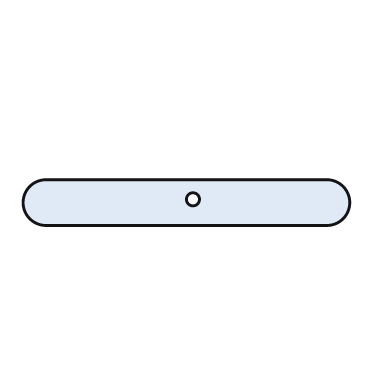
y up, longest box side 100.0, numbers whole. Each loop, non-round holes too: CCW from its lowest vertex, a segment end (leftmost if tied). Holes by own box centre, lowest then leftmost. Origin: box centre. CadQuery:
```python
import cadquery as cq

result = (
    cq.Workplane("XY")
    .moveTo(-43.0, -7.0)
    .lineTo(43.0, -7.0)
    .threePointArc((50.0, 0.0), (43.0, 7.0))
    .lineTo(-43.0, 7.0)
    .threePointArc((-50.0, 0.0), (-43.0, -7.0))
    .close()
    .moveTo(2.0, 1.0)
    .circle(2.0)
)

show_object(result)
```